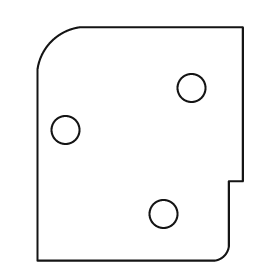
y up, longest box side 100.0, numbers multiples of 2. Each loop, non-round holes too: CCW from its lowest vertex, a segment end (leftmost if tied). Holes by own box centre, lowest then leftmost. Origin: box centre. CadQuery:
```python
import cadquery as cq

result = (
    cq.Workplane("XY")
    .moveTo(-44.0, -50.0)
    .lineTo(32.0, -50.0)
    .threePointArc((36.0, -48.0), (38.0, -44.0))
    .lineTo(38.0, -16.0)
    .lineTo(44.0, -16.0)
    .lineTo(44.0, 50.0)
    .lineTo(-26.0, 50.0)
    .threePointArc((-38.0, 44.0), (-44.0, 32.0))
    .close()
    .moveTo(10.0, -30.0)
    .circle(6.0)
    .moveTo(-32.0, 6.0)
    .circle(6.0)
    .moveTo(22.0, 24.0)
    .circle(6.0)
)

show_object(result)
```